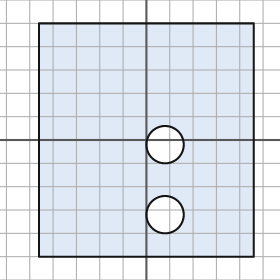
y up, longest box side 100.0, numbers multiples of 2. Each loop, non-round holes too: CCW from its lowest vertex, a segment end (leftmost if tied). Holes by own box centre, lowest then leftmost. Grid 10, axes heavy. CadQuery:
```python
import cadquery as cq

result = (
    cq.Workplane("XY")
    .moveTo(-46.0, -50.0)
    .lineTo(46.0, -50.0)
    .lineTo(46.0, 50.0)
    .lineTo(-46.0, 50.0)
    .close()
    .moveTo(8.0, -32.0)
    .circle(8.0)
    .moveTo(8.0, -2.0)
    .circle(8.0)
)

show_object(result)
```